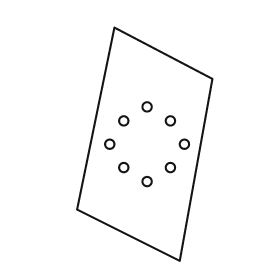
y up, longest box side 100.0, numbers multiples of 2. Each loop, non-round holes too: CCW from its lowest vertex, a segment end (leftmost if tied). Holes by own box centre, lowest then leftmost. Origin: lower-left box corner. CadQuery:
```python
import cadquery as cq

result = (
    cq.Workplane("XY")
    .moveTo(44.0, 0.0)
    .lineTo(58.0, 78.0)
    .lineTo(16.0, 100.0)
    .lineTo(0.0, 22.0)
    .close()
    .moveTo(30.0, 34.0)
    .circle(2.0)
    .moveTo(20.0, 40.0)
    .circle(2.0)
    .moveTo(40.0, 40.0)
    .circle(2.0)
    .moveTo(14.0, 50.0)
    .circle(2.0)
    .moveTo(46.0, 50.0)
    .circle(2.0)
    .moveTo(20.0, 60.0)
    .circle(2.0)
    .moveTo(40.0, 60.0)
    .circle(2.0)
    .moveTo(30.0, 66.0)
    .circle(2.0)
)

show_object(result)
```